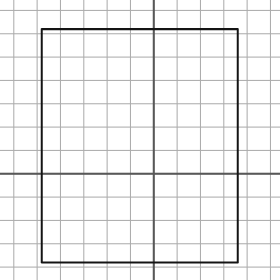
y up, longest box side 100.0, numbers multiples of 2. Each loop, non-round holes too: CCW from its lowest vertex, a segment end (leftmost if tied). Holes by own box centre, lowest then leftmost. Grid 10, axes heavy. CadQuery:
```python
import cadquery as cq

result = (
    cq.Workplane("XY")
    .moveTo(-48.0, -38.0)
    .lineTo(36.0, -38.0)
    .lineTo(36.0, 62.0)
    .lineTo(-48.0, 62.0)
    .close()
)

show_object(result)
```